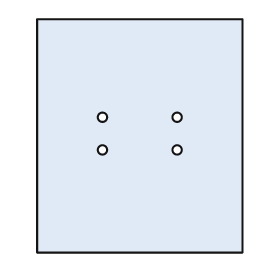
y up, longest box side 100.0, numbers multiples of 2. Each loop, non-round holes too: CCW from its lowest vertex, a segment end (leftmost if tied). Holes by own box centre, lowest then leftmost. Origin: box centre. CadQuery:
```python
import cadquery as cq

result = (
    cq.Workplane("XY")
    .moveTo(-44.0, -50.0)
    .lineTo(44.0, -50.0)
    .lineTo(44.0, 50.0)
    .lineTo(-44.0, 50.0)
    .close()
    .moveTo(-16.0, -6.0)
    .circle(2.0)
    .moveTo(16.0, -6.0)
    .circle(2.0)
    .moveTo(-16.0, 8.0)
    .circle(2.0)
    .moveTo(16.0, 8.0)
    .circle(2.0)
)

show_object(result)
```